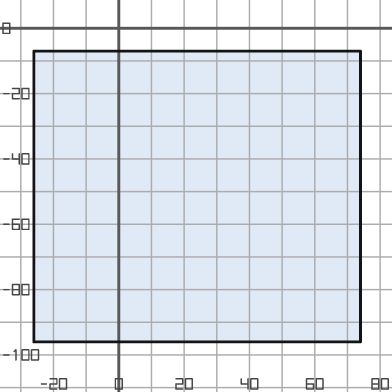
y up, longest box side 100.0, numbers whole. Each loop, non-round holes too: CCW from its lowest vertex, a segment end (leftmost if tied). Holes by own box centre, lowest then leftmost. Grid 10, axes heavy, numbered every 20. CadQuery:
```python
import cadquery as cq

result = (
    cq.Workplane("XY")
    .moveTo(-26.0, -96.0)
    .lineTo(74.0, -96.0)
    .lineTo(74.0, -7.0)
    .lineTo(-26.0, -7.0)
    .close()
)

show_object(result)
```